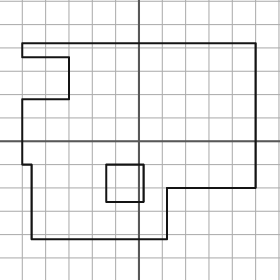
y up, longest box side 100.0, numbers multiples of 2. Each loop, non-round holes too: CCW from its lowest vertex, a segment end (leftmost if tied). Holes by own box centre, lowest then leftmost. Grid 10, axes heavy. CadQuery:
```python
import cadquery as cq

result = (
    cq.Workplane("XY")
    .moveTo(-46.0, -42.0)
    .lineTo(12.0, -42.0)
    .lineTo(12.0, -20.0)
    .lineTo(50.0, -20.0)
    .lineTo(50.0, 42.0)
    .lineTo(-50.0, 42.0)
    .lineTo(-50.0, 36.0)
    .lineTo(-30.0, 36.0)
    .lineTo(-30.0, 18.0)
    .lineTo(-50.0, 18.0)
    .lineTo(-50.0, -10.0)
    .lineTo(-46.0, -10.0)
    .close()
    .moveTo(-14.0, -26.0)
    .lineTo(2.0, -26.0)
    .lineTo(2.0, -10.0)
    .lineTo(-14.0, -10.0)
    .close()
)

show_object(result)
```